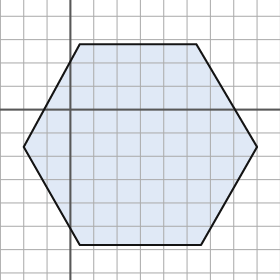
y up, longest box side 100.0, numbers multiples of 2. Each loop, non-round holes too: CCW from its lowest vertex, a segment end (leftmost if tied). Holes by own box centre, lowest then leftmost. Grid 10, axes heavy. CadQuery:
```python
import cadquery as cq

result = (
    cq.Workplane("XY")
    .moveTo(4.0, -58.0)
    .lineTo(56.0, -58.0)
    .lineTo(80.0, -16.0)
    .lineTo(54.0, 28.0)
    .lineTo(4.0, 28.0)
    .lineTo(-20.0, -16.0)
    .close()
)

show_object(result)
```